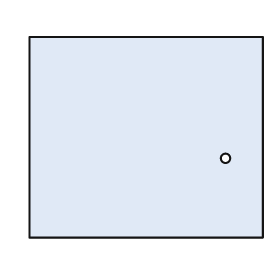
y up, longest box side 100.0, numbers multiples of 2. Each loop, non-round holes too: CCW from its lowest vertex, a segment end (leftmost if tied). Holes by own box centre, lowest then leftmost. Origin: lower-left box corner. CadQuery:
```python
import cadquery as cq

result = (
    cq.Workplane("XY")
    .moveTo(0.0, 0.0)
    .lineTo(100.0, 0.0)
    .lineTo(100.0, 86.0)
    .lineTo(0.0, 86.0)
    .close()
    .moveTo(84.0, 34.0)
    .circle(2.0)
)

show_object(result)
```